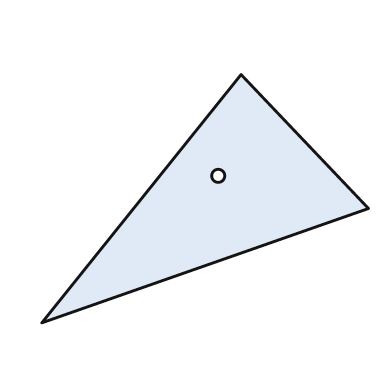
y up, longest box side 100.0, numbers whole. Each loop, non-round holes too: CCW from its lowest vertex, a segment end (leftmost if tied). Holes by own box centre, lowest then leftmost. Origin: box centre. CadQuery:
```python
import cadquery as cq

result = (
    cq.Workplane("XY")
    .moveTo(-50.0, -38.0)
    .lineTo(50.0, -3.0)
    .lineTo(11.0, 38.0)
    .close()
    .moveTo(4.0, 7.0)
    .circle(2.0)
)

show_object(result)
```